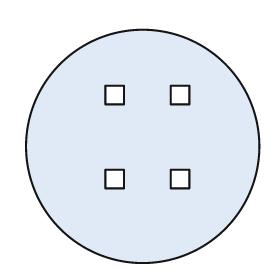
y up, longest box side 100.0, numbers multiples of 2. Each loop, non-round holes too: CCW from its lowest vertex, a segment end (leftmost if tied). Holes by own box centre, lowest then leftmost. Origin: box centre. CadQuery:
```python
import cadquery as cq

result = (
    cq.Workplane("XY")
    .moveTo(0.0, 0.0)
    .circle(50.0)
    .moveTo(-16.0, -18.0)
    .lineTo(-8.0, -18.0)
    .lineTo(-8.0, -10.0)
    .lineTo(-16.0, -10.0)
    .close()
    .moveTo(12.0, -18.0)
    .lineTo(20.0, -18.0)
    .lineTo(20.0, -10.0)
    .lineTo(12.0, -10.0)
    .close()
    .moveTo(-16.0, 18.0)
    .lineTo(-8.0, 18.0)
    .lineTo(-8.0, 26.0)
    .lineTo(-16.0, 26.0)
    .close()
    .moveTo(12.0, 18.0)
    .lineTo(20.0, 18.0)
    .lineTo(20.0, 26.0)
    .lineTo(12.0, 26.0)
    .close()
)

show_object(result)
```